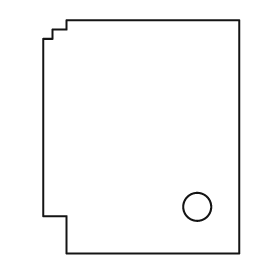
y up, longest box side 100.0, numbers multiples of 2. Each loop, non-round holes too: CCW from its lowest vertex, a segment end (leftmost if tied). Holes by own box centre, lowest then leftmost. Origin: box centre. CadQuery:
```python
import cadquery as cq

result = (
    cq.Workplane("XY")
    .moveTo(-32.0, -50.0)
    .lineTo(42.0, -50.0)
    .lineTo(42.0, 50.0)
    .lineTo(-32.0, 50.0)
    .lineTo(-32.0, 46.0)
    .lineTo(-38.0, 46.0)
    .lineTo(-38.0, 42.0)
    .lineTo(-42.0, 42.0)
    .lineTo(-42.0, -34.0)
    .lineTo(-32.0, -34.0)
    .close()
    .moveTo(24.0, -30.0)
    .circle(6.0)
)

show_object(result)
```